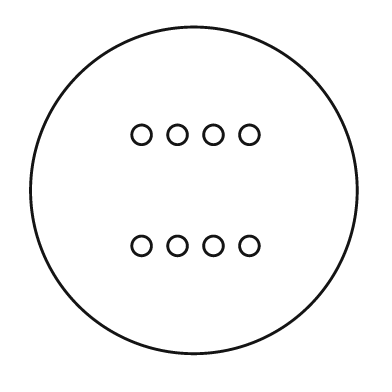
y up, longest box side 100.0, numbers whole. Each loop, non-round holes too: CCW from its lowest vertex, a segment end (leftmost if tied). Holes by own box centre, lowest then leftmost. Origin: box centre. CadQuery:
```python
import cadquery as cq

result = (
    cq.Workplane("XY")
    .moveTo(0.0, 0.0)
    .circle(50.0)
    .moveTo(-16.0, -17.0)
    .circle(3.0)
    .moveTo(-5.0, -17.0)
    .circle(3.0)
    .moveTo(6.0, -17.0)
    .circle(3.0)
    .moveTo(17.0, -17.0)
    .circle(3.0)
    .moveTo(-16.0, 17.0)
    .circle(3.0)
    .moveTo(-5.0, 17.0)
    .circle(3.0)
    .moveTo(6.0, 17.0)
    .circle(3.0)
    .moveTo(17.0, 17.0)
    .circle(3.0)
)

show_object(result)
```